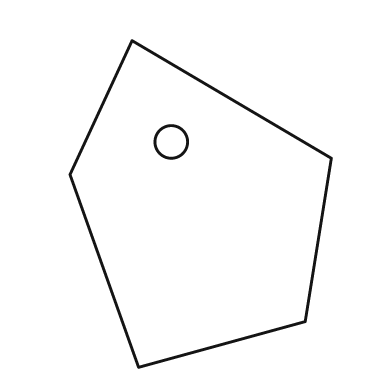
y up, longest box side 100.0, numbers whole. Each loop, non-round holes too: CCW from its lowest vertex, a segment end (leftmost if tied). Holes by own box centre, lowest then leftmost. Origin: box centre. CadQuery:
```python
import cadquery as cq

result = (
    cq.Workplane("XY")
    .moveTo(-19.0, -50.0)
    .lineTo(32.0, -36.0)
    .lineTo(40.0, 14.0)
    .lineTo(-21.0, 50.0)
    .lineTo(-40.0, 9.0)
    .close()
    .moveTo(-9.0, 19.0)
    .circle(5.0)
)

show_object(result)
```